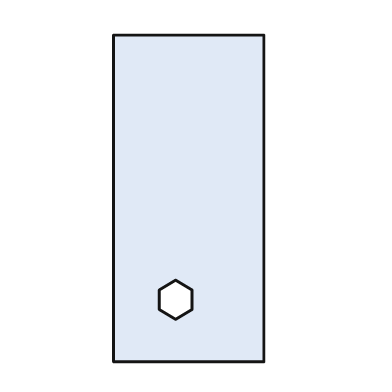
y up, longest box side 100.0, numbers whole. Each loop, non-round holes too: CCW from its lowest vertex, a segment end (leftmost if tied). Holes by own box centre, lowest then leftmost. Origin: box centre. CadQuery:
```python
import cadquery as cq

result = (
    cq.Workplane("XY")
    .moveTo(-23.0, -50.0)
    .lineTo(23.0, -50.0)
    .lineTo(23.0, 50.0)
    .lineTo(-23.0, 50.0)
    .close()
    .moveTo(-4.0, -37.0)
    .lineTo(1.0, -34.0)
    .lineTo(1.0, -28.0)
    .lineTo(-4.0, -25.0)
    .lineTo(-9.0, -28.0)
    .lineTo(-9.0, -34.0)
    .close()
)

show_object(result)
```